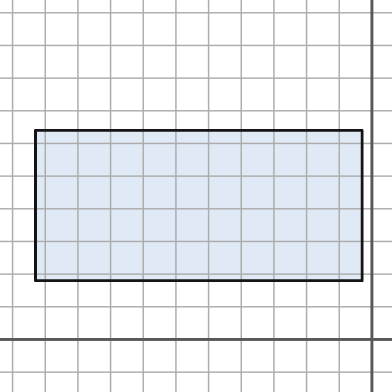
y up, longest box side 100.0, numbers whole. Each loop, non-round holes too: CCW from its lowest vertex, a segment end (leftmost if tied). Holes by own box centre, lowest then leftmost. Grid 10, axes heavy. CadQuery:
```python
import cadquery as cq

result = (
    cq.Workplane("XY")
    .moveTo(-103.0, 18.0)
    .lineTo(-3.0, 18.0)
    .lineTo(-3.0, 64.0)
    .lineTo(-103.0, 64.0)
    .close()
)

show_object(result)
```